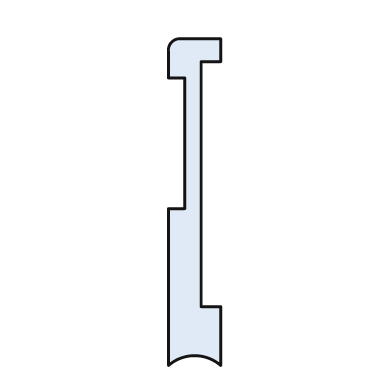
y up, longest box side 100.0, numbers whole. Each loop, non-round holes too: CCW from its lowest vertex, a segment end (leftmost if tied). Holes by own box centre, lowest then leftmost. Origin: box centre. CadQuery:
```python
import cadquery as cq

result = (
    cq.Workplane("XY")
    .moveTo(-8.0, -50.0)
    .threePointArc((0.0, -47.0), (8.0, -50.0))
    .lineTo(8.0, -32.0)
    .lineTo(2.0, -32.0)
    .lineTo(2.0, 43.0)
    .lineTo(8.0, 43.0)
    .lineTo(8.0, 50.0)
    .lineTo(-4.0, 50.0)
    .threePointArc((-7.0, 49.0), (-8.0, 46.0))
    .lineTo(-8.0, 38.0)
    .lineTo(-3.0, 38.0)
    .lineTo(-3.0, -2.0)
    .lineTo(-8.0, -2.0)
    .close()
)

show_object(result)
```